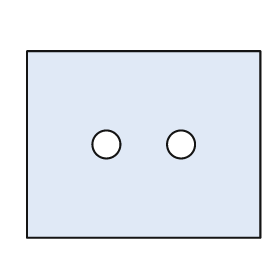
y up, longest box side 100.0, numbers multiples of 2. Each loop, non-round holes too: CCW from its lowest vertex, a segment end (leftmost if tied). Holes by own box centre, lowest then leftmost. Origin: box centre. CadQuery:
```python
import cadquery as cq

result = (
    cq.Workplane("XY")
    .moveTo(-50.0, -40.0)
    .lineTo(50.0, -40.0)
    .lineTo(50.0, 40.0)
    .lineTo(-50.0, 40.0)
    .close()
    .moveTo(-16.0, 0.0)
    .circle(6.0)
    .moveTo(16.0, 0.0)
    .circle(6.0)
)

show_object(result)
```